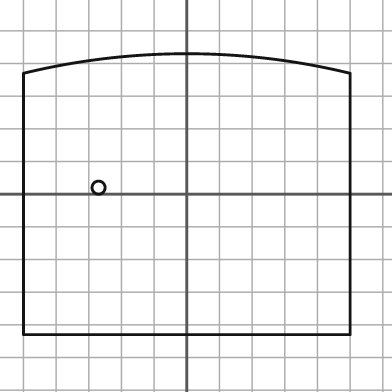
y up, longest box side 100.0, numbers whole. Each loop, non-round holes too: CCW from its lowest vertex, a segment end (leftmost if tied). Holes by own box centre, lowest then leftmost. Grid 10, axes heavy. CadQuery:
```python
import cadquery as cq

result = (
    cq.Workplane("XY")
    .moveTo(-50.0, -43.0)
    .lineTo(50.0, -43.0)
    .lineTo(50.0, 37.0)
    .threePointArc((0.0, 43.0), (-50.0, 37.0))
    .close()
    .moveTo(-27.0, 2.0)
    .circle(2.0)
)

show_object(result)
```